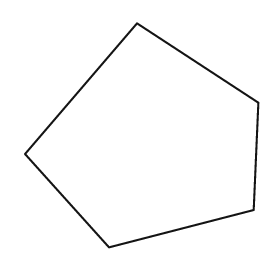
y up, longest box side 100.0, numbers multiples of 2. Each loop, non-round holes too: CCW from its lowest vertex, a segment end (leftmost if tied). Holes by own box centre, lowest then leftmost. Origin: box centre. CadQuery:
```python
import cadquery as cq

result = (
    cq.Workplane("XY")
    .moveTo(-14.0, -48.0)
    .lineTo(48.0, -32.0)
    .lineTo(50.0, 14.0)
    .lineTo(-2.0, 48.0)
    .lineTo(-50.0, -8.0)
    .close()
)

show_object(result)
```